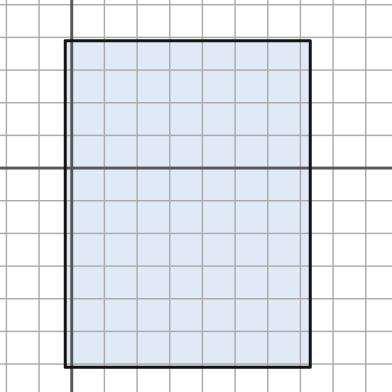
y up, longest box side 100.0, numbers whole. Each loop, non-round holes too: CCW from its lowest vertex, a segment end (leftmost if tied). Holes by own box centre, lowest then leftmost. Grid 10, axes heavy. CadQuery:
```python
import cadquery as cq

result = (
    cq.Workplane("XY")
    .moveTo(-2.0, -61.0)
    .lineTo(73.0, -61.0)
    .lineTo(73.0, 39.0)
    .lineTo(-2.0, 39.0)
    .close()
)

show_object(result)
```